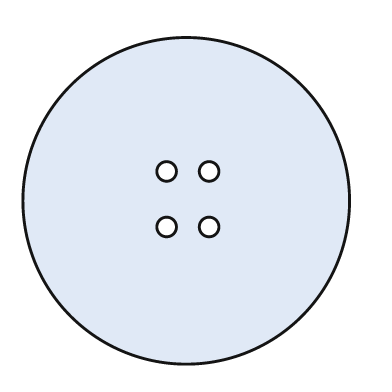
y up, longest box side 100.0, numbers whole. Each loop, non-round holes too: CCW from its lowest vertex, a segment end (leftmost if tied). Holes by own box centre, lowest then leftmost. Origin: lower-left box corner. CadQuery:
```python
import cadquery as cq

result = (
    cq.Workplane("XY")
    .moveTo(50.0, 50.0)
    .circle(50.0)
    .moveTo(44.0, 42.0)
    .circle(3.0)
    .moveTo(57.0, 42.0)
    .circle(3.0)
    .moveTo(44.0, 59.0)
    .circle(3.0)
    .moveTo(57.0, 59.0)
    .circle(3.0)
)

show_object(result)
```